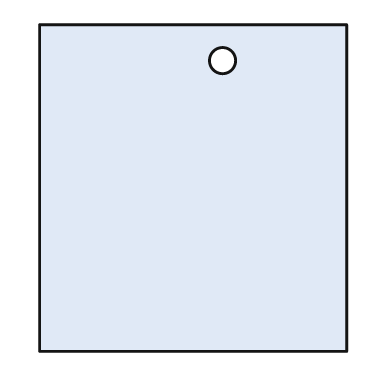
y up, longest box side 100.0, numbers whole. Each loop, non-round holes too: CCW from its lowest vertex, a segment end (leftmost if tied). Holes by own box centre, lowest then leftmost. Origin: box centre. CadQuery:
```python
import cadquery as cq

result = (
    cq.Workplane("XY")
    .moveTo(-47.0, -50.0)
    .lineTo(47.0, -50.0)
    .lineTo(47.0, 50.0)
    .lineTo(-47.0, 50.0)
    .close()
    .moveTo(9.0, 39.0)
    .circle(4.0)
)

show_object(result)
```